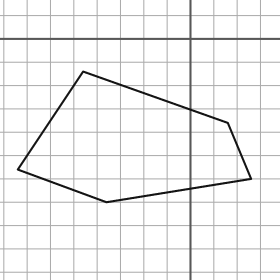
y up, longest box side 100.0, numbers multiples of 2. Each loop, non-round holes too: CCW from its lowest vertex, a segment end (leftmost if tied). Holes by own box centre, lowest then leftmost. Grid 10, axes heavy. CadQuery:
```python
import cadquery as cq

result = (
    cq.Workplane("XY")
    .moveTo(-36.0, -70.0)
    .lineTo(26.0, -60.0)
    .lineTo(16.0, -36.0)
    .lineTo(-46.0, -14.0)
    .lineTo(-74.0, -56.0)
    .close()
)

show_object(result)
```